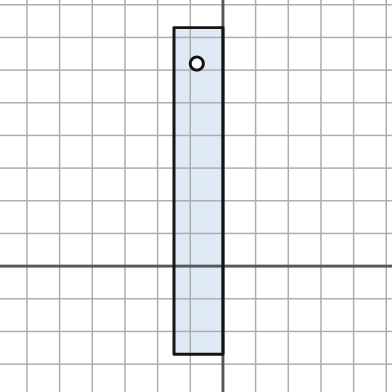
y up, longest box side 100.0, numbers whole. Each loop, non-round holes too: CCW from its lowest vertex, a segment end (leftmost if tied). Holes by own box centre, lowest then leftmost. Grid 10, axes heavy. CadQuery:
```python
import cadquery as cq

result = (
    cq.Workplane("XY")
    .moveTo(-15.0, -27.0)
    .lineTo(0.0, -27.0)
    .lineTo(0.0, 73.0)
    .lineTo(-15.0, 73.0)
    .close()
    .moveTo(-8.0, 62.0)
    .circle(2.0)
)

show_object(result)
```